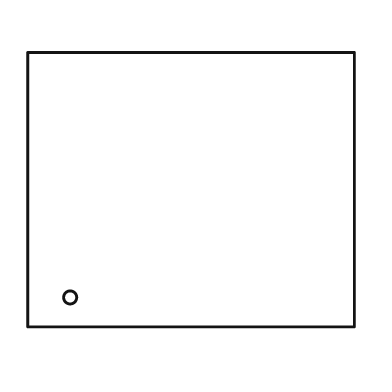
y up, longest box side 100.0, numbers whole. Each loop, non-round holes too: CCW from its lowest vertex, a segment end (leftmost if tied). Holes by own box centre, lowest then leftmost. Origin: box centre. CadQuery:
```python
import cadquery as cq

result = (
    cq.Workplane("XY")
    .moveTo(-50.0, -42.0)
    .lineTo(50.0, -42.0)
    .lineTo(50.0, 42.0)
    .lineTo(-50.0, 42.0)
    .close()
    .moveTo(-37.0, -33.0)
    .circle(2.0)
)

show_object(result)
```